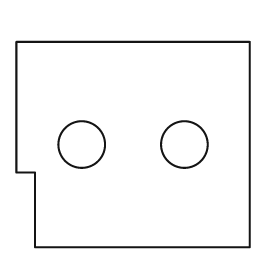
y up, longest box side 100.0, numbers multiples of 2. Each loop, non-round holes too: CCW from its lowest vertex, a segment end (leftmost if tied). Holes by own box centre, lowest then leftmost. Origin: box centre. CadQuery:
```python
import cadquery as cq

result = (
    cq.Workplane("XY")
    .moveTo(-42.0, -44.0)
    .lineTo(50.0, -44.0)
    .lineTo(50.0, 44.0)
    .lineTo(-50.0, 44.0)
    .lineTo(-50.0, -12.0)
    .lineTo(-42.0, -12.0)
    .close()
    .moveTo(-22.0, 0.0)
    .circle(10.0)
    .moveTo(22.0, 0.0)
    .circle(10.0)
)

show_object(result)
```